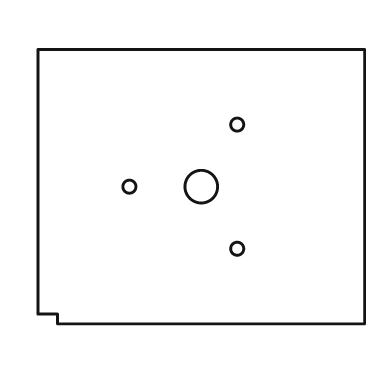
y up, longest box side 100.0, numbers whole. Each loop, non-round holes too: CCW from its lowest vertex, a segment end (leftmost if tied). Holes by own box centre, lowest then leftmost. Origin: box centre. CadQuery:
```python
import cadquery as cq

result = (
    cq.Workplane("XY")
    .moveTo(-44.0, -42.0)
    .lineTo(50.0, -42.0)
    .lineTo(50.0, 42.0)
    .lineTo(-50.0, 42.0)
    .lineTo(-50.0, -39.0)
    .lineTo(-44.0, -39.0)
    .close()
    .moveTo(11.0, -19.0)
    .circle(2.0)
    .moveTo(-22.0, 0.0)
    .circle(2.0)
    .moveTo(0.0, 0.0)
    .circle(5.0)
    .moveTo(11.0, 19.0)
    .circle(2.0)
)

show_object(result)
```